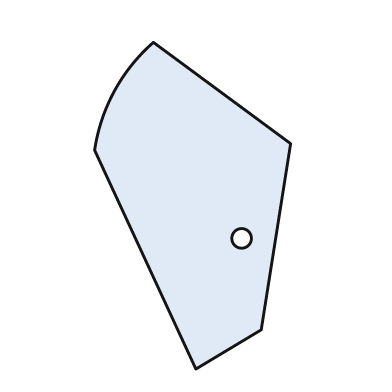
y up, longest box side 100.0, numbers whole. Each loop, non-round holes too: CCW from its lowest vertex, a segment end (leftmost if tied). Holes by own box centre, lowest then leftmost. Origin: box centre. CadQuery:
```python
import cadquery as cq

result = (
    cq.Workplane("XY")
    .moveTo(1.0, -50.0)
    .lineTo(21.0, -38.0)
    .lineTo(30.0, 19.0)
    .lineTo(-12.0, 50.0)
    .threePointArc((-24.0, 35.0), (-30.0, 17.0))
    .close()
    .moveTo(15.0, -10.0)
    .circle(3.0)
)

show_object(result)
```